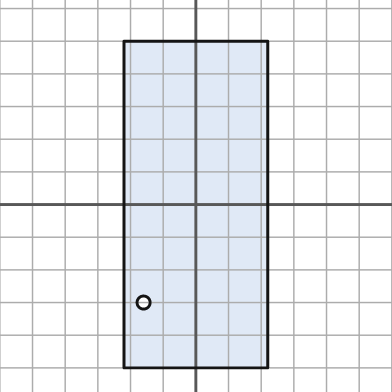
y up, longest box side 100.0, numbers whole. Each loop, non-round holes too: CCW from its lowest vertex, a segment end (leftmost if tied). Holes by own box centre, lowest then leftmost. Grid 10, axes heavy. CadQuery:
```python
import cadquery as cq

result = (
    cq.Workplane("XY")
    .moveTo(-22.0, -50.0)
    .lineTo(22.0, -50.0)
    .lineTo(22.0, 50.0)
    .lineTo(-22.0, 50.0)
    .close()
    .moveTo(-16.0, -30.0)
    .circle(2.0)
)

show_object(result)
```